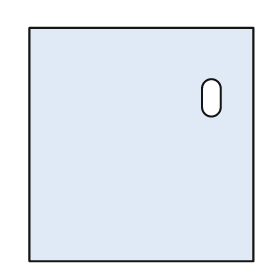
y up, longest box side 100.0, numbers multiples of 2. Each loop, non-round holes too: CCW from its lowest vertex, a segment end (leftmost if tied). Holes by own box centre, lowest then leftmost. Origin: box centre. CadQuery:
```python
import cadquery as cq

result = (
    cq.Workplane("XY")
    .moveTo(-48.0, -50.0)
    .lineTo(48.0, -50.0)
    .lineTo(48.0, 50.0)
    .lineTo(-48.0, 50.0)
    .close()
    .moveTo(26.0, 16.0)
    .threePointArc((30.0, 12.0), (34.0, 16.0))
    .lineTo(34.0, 24.0)
    .threePointArc((30.0, 28.0), (26.0, 24.0))
    .close()
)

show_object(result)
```